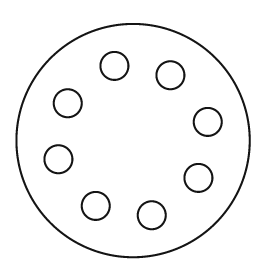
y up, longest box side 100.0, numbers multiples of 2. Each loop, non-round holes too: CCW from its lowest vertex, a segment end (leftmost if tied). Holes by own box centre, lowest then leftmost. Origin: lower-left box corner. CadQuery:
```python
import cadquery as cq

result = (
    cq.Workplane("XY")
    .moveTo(50.0, 50.0)
    .circle(50.0)
    .moveTo(58.0, 18.0)
    .circle(6.0)
    .moveTo(34.0, 22.0)
    .circle(6.0)
    .moveTo(78.0, 34.0)
    .circle(6.0)
    .moveTo(18.0, 42.0)
    .circle(6.0)
    .moveTo(82.0, 58.0)
    .circle(6.0)
    .moveTo(22.0, 66.0)
    .circle(6.0)
    .moveTo(66.0, 78.0)
    .circle(6.0)
    .moveTo(42.0, 82.0)
    .circle(6.0)
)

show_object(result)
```